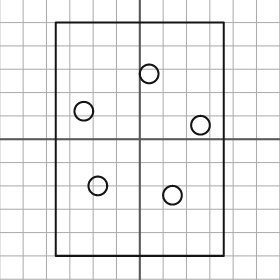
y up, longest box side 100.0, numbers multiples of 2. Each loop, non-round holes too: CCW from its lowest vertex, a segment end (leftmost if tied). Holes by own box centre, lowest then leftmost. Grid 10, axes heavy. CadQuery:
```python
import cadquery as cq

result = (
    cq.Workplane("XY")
    .moveTo(-36.0, -50.0)
    .lineTo(36.0, -50.0)
    .lineTo(36.0, 50.0)
    .lineTo(-36.0, 50.0)
    .close()
    .moveTo(14.0, -24.0)
    .circle(4.0)
    .moveTo(-18.0, -20.0)
    .circle(4.0)
    .moveTo(26.0, 6.0)
    .circle(4.0)
    .moveTo(-24.0, 12.0)
    .circle(4.0)
    .moveTo(4.0, 28.0)
    .circle(4.0)
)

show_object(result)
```